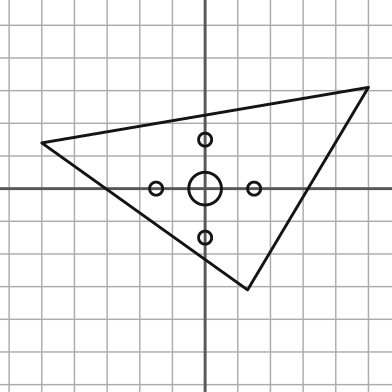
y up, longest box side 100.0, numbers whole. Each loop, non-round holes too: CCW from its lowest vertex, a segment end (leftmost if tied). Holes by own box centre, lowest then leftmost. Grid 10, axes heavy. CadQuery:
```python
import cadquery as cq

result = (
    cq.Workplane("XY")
    .moveTo(13.0, -31.0)
    .lineTo(50.0, 31.0)
    .lineTo(-50.0, 14.0)
    .close()
    .moveTo(0.0, -15.0)
    .circle(2.0)
    .moveTo(-15.0, 0.0)
    .circle(2.0)
    .moveTo(0.0, 0.0)
    .circle(5.0)
    .moveTo(15.0, 0.0)
    .circle(2.0)
    .moveTo(0.0, 15.0)
    .circle(2.0)
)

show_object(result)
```